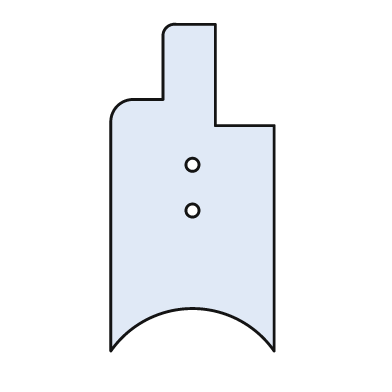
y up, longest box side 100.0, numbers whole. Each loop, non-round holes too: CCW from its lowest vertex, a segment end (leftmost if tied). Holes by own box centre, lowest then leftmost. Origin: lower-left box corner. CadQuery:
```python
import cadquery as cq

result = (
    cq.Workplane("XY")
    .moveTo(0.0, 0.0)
    .threePointArc((25.0, 13.0), (50.0, 0.0))
    .lineTo(50.0, 69.0)
    .lineTo(32.0, 69.0)
    .lineTo(32.0, 100.0)
    .lineTo(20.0, 100.0)
    .threePointArc((17.0, 99.0), (16.0, 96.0))
    .lineTo(16.0, 77.0)
    .lineTo(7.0, 77.0)
    .threePointArc((2.0, 75.0), (0.0, 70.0))
    .close()
    .moveTo(25.0, 43.0)
    .circle(2.0)
    .moveTo(25.0, 57.0)
    .circle(2.0)
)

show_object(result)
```